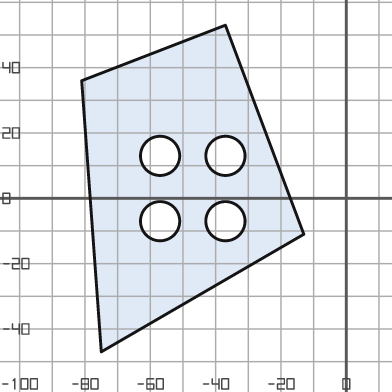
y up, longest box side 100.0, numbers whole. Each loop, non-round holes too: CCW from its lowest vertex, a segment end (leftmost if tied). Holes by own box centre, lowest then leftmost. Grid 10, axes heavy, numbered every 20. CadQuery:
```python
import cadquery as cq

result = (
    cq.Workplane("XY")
    .moveTo(-75.0, -47.0)
    .lineTo(-13.0, -11.0)
    .lineTo(-37.0, 53.0)
    .lineTo(-81.0, 36.0)
    .close()
    .moveTo(-57.0, -7.0)
    .circle(6.0)
    .moveTo(-37.0, -7.0)
    .circle(6.0)
    .moveTo(-57.0, 13.0)
    .circle(6.0)
    .moveTo(-37.0, 13.0)
    .circle(6.0)
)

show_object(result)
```